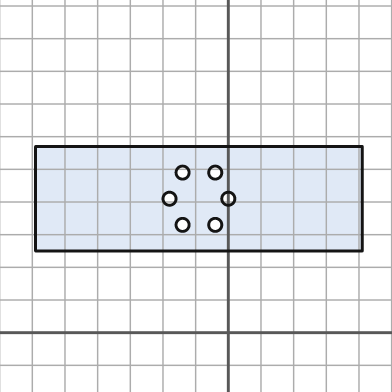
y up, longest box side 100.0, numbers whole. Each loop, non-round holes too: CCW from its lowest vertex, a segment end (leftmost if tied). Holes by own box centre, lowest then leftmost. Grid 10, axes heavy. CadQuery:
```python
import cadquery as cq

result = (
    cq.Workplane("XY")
    .moveTo(-59.0, 25.0)
    .lineTo(41.0, 25.0)
    .lineTo(41.0, 57.0)
    .lineTo(-59.0, 57.0)
    .close()
    .moveTo(-14.0, 33.0)
    .circle(2.0)
    .moveTo(-4.0, 33.0)
    .circle(2.0)
    .moveTo(-18.0, 41.0)
    .circle(2.0)
    .moveTo(0.0, 41.0)
    .circle(2.0)
    .moveTo(-14.0, 49.0)
    .circle(2.0)
    .moveTo(-4.0, 49.0)
    .circle(2.0)
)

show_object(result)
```